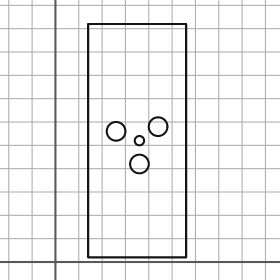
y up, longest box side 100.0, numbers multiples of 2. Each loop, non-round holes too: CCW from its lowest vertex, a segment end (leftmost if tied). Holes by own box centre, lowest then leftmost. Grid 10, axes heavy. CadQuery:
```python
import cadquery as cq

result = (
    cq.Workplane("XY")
    .moveTo(14.0, 2.0)
    .lineTo(56.0, 2.0)
    .lineTo(56.0, 102.0)
    .lineTo(14.0, 102.0)
    .close()
    .moveTo(36.0, 42.0)
    .circle(4.0)
    .moveTo(36.0, 52.0)
    .circle(2.0)
    .moveTo(26.0, 56.0)
    .circle(4.0)
    .moveTo(44.0, 58.0)
    .circle(4.0)
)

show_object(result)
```